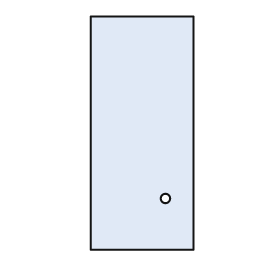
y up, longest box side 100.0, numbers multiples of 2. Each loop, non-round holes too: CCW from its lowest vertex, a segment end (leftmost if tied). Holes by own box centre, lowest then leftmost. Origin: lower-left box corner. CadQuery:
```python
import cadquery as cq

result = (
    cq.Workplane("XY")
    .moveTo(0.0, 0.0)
    .lineTo(44.0, 0.0)
    .lineTo(44.0, 100.0)
    .lineTo(0.0, 100.0)
    .close()
    .moveTo(32.0, 22.0)
    .circle(2.0)
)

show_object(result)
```